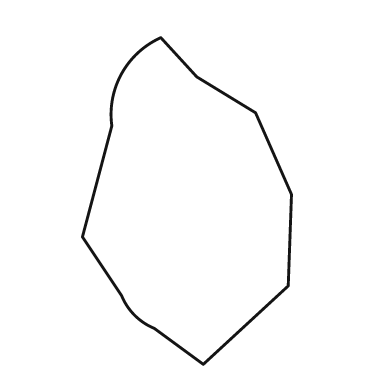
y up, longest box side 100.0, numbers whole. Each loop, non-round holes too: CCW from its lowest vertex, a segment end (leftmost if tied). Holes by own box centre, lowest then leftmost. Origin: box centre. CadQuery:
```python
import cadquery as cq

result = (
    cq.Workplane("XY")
    .moveTo(5.0, -50.0)
    .lineTo(31.0, -26.0)
    .lineTo(32.0, 2.0)
    .lineTo(21.0, 27.0)
    .lineTo(3.0, 38.0)
    .lineTo(-8.0, 50.0)
    .threePointArc((-20.0, 39.0), (-23.0, 23.0))
    .lineTo(-32.0, -11.0)
    .lineTo(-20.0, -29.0)
    .threePointArc((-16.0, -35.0), (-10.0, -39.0))
    .close()
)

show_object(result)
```